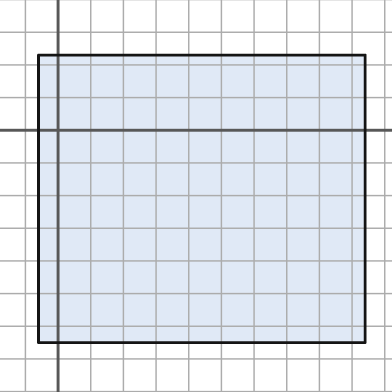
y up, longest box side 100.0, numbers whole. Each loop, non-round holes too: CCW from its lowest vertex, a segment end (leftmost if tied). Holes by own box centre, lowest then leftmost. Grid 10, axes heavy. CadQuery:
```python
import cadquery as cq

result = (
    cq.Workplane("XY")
    .moveTo(-6.0, -65.0)
    .lineTo(94.0, -65.0)
    .lineTo(94.0, 23.0)
    .lineTo(-6.0, 23.0)
    .close()
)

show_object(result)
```